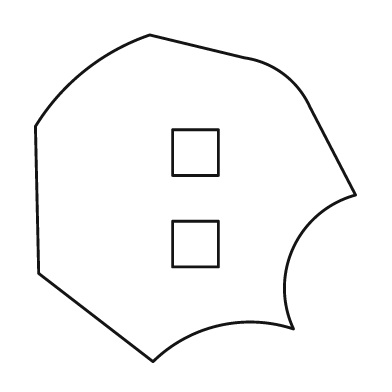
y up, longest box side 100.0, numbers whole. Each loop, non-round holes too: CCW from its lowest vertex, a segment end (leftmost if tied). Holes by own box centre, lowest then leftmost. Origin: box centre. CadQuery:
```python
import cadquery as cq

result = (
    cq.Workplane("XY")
    .moveTo(-13.0, -50.0)
    .threePointArc((7.0, -39.0), (30.0, -40.0))
    .threePointArc((30.0, -15.0), (49.0, 1.0))
    .lineTo(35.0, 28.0)
    .threePointArc((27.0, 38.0), (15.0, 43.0))
    .lineTo(-14.0, 50.0)
    .threePointArc((-34.0, 39.0), (-49.0, 22.0))
    .lineTo(-48.0, -23.0)
    .close()
    .moveTo(-7.0, -21.0)
    .lineTo(7.0, -21.0)
    .lineTo(7.0, -7.0)
    .lineTo(-7.0, -7.0)
    .close()
    .moveTo(-7.0, 7.0)
    .lineTo(7.0, 7.0)
    .lineTo(7.0, 21.0)
    .lineTo(-7.0, 21.0)
    .close()
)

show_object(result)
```